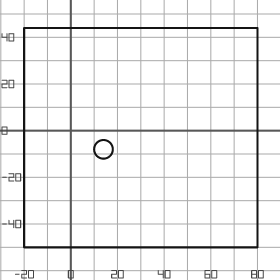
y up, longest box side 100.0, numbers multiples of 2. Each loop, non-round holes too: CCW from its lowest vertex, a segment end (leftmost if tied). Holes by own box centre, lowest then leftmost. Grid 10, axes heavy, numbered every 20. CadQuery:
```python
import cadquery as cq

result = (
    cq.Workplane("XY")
    .moveTo(-20.0, -50.0)
    .lineTo(80.0, -50.0)
    .lineTo(80.0, 44.0)
    .lineTo(-20.0, 44.0)
    .close()
    .moveTo(14.0, -8.0)
    .circle(4.0)
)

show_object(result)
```